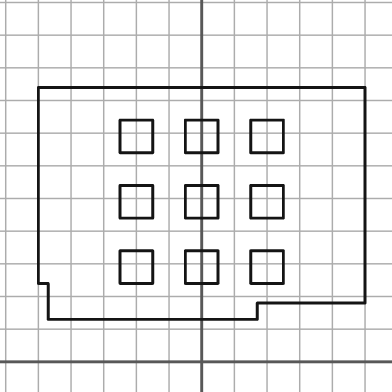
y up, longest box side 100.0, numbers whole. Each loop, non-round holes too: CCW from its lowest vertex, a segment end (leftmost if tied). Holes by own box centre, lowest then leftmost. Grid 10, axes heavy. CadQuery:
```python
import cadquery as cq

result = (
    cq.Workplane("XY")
    .moveTo(-47.0, 13.0)
    .lineTo(17.0, 13.0)
    .lineTo(17.0, 18.0)
    .lineTo(50.0, 18.0)
    .lineTo(50.0, 84.0)
    .lineTo(-50.0, 84.0)
    .lineTo(-50.0, 24.0)
    .lineTo(-47.0, 24.0)
    .close()
    .moveTo(-25.0, 24.0)
    .lineTo(-15.0, 24.0)
    .lineTo(-15.0, 34.0)
    .lineTo(-25.0, 34.0)
    .close()
    .moveTo(-5.0, 24.0)
    .lineTo(5.0, 24.0)
    .lineTo(5.0, 34.0)
    .lineTo(-5.0, 34.0)
    .close()
    .moveTo(15.0, 24.0)
    .lineTo(25.0, 24.0)
    .lineTo(25.0, 34.0)
    .lineTo(15.0, 34.0)
    .close()
    .moveTo(-25.0, 44.0)
    .lineTo(-15.0, 44.0)
    .lineTo(-15.0, 54.0)
    .lineTo(-25.0, 54.0)
    .close()
    .moveTo(-5.0, 44.0)
    .lineTo(5.0, 44.0)
    .lineTo(5.0, 54.0)
    .lineTo(-5.0, 54.0)
    .close()
    .moveTo(15.0, 44.0)
    .lineTo(25.0, 44.0)
    .lineTo(25.0, 54.0)
    .lineTo(15.0, 54.0)
    .close()
    .moveTo(-25.0, 64.0)
    .lineTo(-15.0, 64.0)
    .lineTo(-15.0, 74.0)
    .lineTo(-25.0, 74.0)
    .close()
    .moveTo(-5.0, 64.0)
    .lineTo(5.0, 64.0)
    .lineTo(5.0, 74.0)
    .lineTo(-5.0, 74.0)
    .close()
    .moveTo(15.0, 64.0)
    .lineTo(25.0, 64.0)
    .lineTo(25.0, 74.0)
    .lineTo(15.0, 74.0)
    .close()
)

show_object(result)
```